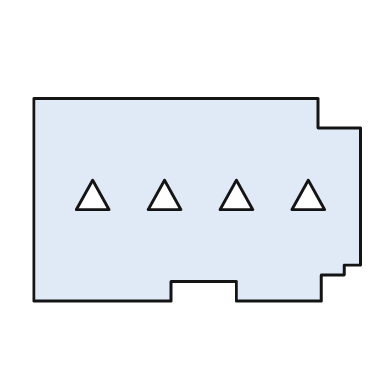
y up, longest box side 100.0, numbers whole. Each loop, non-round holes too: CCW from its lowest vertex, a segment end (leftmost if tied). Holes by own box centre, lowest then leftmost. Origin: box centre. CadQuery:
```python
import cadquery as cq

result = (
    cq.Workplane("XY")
    .moveTo(-50.0, -31.0)
    .lineTo(-8.0, -31.0)
    .lineTo(-8.0, -25.0)
    .lineTo(12.0, -25.0)
    .lineTo(12.0, -31.0)
    .lineTo(38.0, -31.0)
    .lineTo(38.0, -23.0)
    .lineTo(45.0, -23.0)
    .lineTo(45.0, -20.0)
    .lineTo(50.0, -20.0)
    .lineTo(50.0, 22.0)
    .lineTo(37.0, 22.0)
    .lineTo(37.0, 31.0)
    .lineTo(-50.0, 31.0)
    .close()
    .moveTo(-37.0, -3.0)
    .lineTo(-27.0, -3.0)
    .lineTo(-32.0, 6.0)
    .close()
    .moveTo(-15.0, -3.0)
    .lineTo(-5.0, -3.0)
    .lineTo(-10.0, 6.0)
    .close()
    .moveTo(7.0, -3.0)
    .lineTo(17.0, -3.0)
    .lineTo(12.0, 6.0)
    .close()
    .moveTo(29.0, -3.0)
    .lineTo(39.0, -3.0)
    .lineTo(34.0, 6.0)
    .close()
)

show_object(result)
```